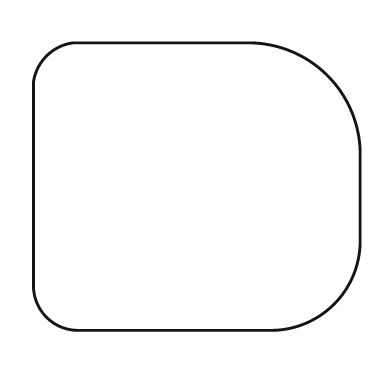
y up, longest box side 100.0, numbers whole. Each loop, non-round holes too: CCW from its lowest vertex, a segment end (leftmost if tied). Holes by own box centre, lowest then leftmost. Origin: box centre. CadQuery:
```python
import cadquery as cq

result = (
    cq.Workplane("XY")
    .moveTo(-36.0, -44.0)
    .lineTo(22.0, -44.0)
    .threePointArc((42.0, -36.0), (50.0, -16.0))
    .lineTo(50.0, 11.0)
    .threePointArc((40.0, 34.0), (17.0, 44.0))
    .lineTo(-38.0, 44.0)
    .threePointArc((-46.0, 40.0), (-50.0, 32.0))
    .lineTo(-50.0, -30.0)
    .threePointArc((-46.0, -40.0), (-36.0, -44.0))
    .close()
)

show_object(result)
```